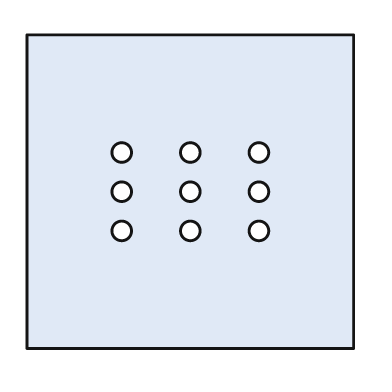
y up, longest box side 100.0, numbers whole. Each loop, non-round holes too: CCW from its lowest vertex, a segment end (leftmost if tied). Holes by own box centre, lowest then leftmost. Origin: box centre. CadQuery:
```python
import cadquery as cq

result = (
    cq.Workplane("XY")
    .moveTo(-50.0, -48.0)
    .lineTo(50.0, -48.0)
    .lineTo(50.0, 48.0)
    .lineTo(-50.0, 48.0)
    .close()
    .moveTo(-21.0, -12.0)
    .circle(3.0)
    .moveTo(0.0, -12.0)
    .circle(3.0)
    .moveTo(21.0, -12.0)
    .circle(3.0)
    .moveTo(-21.0, 0.0)
    .circle(3.0)
    .moveTo(0.0, 0.0)
    .circle(3.0)
    .moveTo(21.0, 0.0)
    .circle(3.0)
    .moveTo(-21.0, 12.0)
    .circle(3.0)
    .moveTo(0.0, 12.0)
    .circle(3.0)
    .moveTo(21.0, 12.0)
    .circle(3.0)
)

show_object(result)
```